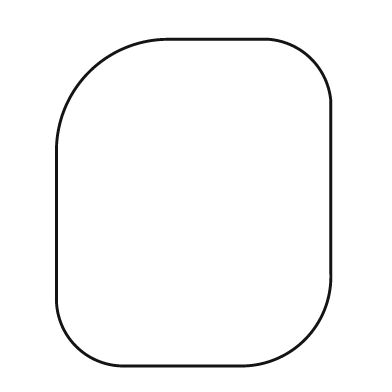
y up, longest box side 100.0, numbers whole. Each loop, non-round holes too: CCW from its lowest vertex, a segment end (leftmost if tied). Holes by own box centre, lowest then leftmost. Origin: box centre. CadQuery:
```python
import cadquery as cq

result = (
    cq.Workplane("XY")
    .moveTo(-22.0, -50.0)
    .lineTo(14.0, -50.0)
    .threePointArc((34.0, -42.0), (42.0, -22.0))
    .lineTo(42.0, 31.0)
    .threePointArc((36.0, 44.0), (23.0, 50.0))
    .lineTo(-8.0, 50.0)
    .threePointArc((-32.0, 40.0), (-42.0, 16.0))
    .lineTo(-42.0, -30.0)
    .threePointArc((-36.0, -44.0), (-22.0, -50.0))
    .close()
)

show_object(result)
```